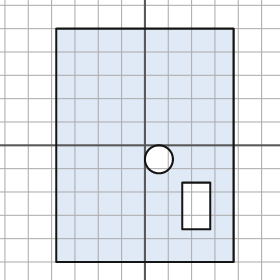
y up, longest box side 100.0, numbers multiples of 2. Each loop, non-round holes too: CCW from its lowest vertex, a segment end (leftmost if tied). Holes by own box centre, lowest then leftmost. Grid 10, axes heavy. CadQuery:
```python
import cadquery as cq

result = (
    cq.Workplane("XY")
    .moveTo(-38.0, -50.0)
    .lineTo(38.0, -50.0)
    .lineTo(38.0, 50.0)
    .lineTo(-38.0, 50.0)
    .close()
    .moveTo(16.0, -36.0)
    .lineTo(28.0, -36.0)
    .lineTo(28.0, -16.0)
    .lineTo(16.0, -16.0)
    .close()
    .moveTo(6.0, -6.0)
    .circle(6.0)
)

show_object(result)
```